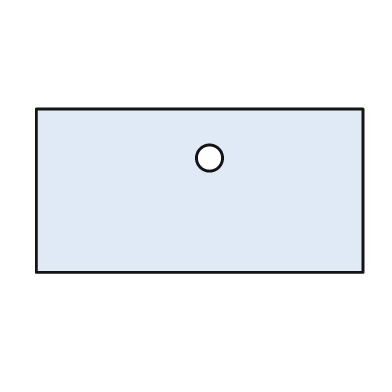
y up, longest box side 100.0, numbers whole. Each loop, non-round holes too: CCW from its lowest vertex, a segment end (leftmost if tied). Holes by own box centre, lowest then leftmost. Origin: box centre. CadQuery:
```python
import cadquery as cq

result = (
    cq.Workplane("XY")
    .moveTo(-50.0, -25.0)
    .lineTo(50.0, -25.0)
    .lineTo(50.0, 25.0)
    .lineTo(-50.0, 25.0)
    .close()
    .moveTo(3.0, 10.0)
    .circle(4.0)
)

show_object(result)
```